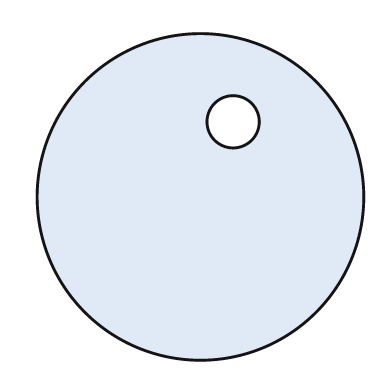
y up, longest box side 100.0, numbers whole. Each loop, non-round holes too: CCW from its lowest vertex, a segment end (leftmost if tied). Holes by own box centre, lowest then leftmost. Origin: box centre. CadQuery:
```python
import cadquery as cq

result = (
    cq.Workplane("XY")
    .moveTo(0.0, 0.0)
    .circle(50.0)
    .moveTo(10.0, 23.0)
    .circle(8.0)
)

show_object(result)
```